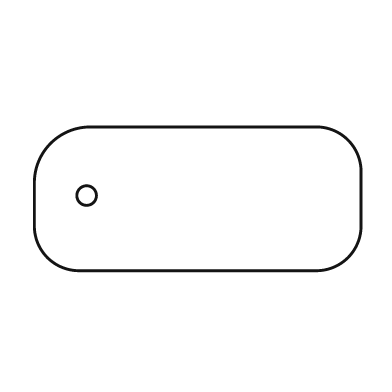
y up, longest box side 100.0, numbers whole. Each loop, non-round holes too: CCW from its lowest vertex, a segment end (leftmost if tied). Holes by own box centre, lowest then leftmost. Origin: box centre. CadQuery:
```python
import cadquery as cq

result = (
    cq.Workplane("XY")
    .moveTo(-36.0, -22.0)
    .lineTo(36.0, -22.0)
    .threePointArc((46.0, -18.0), (50.0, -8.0))
    .lineTo(50.0, 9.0)
    .threePointArc((46.0, 18.0), (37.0, 22.0))
    .lineTo(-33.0, 22.0)
    .threePointArc((-45.0, 17.0), (-50.0, 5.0))
    .lineTo(-50.0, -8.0)
    .threePointArc((-46.0, -18.0), (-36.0, -22.0))
    .close()
    .moveTo(-34.0, 1.0)
    .circle(3.0)
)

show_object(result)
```